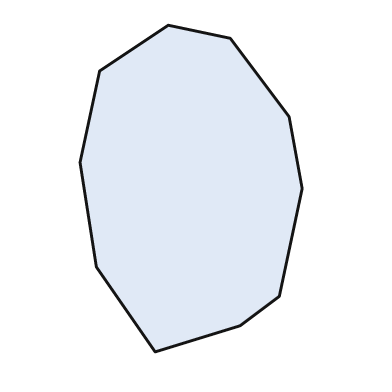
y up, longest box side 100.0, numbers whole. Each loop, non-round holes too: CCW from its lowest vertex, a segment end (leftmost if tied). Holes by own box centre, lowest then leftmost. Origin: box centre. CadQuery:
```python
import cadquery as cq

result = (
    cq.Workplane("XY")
    .moveTo(-11.0, -50.0)
    .lineTo(15.0, -42.0)
    .lineTo(27.0, -33.0)
    .lineTo(34.0, 0.0)
    .lineTo(30.0, 22.0)
    .lineTo(12.0, 46.0)
    .lineTo(-7.0, 50.0)
    .lineTo(-28.0, 36.0)
    .lineTo(-34.0, 8.0)
    .lineTo(-29.0, -24.0)
    .close()
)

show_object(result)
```